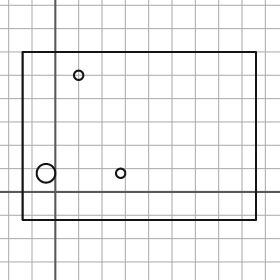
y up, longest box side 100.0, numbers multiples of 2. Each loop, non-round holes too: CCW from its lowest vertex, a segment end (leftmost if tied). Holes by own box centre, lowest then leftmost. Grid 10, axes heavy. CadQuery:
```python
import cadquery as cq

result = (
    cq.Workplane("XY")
    .moveTo(-14.0, -12.0)
    .lineTo(86.0, -12.0)
    .lineTo(86.0, 60.0)
    .lineTo(-14.0, 60.0)
    .close()
    .moveTo(-4.0, 8.0)
    .circle(4.0)
    .moveTo(28.0, 8.0)
    .circle(2.0)
    .moveTo(10.0, 50.0)
    .circle(2.0)
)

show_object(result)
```